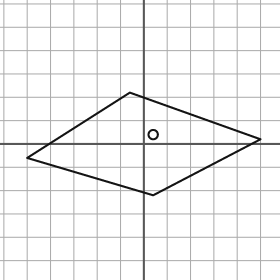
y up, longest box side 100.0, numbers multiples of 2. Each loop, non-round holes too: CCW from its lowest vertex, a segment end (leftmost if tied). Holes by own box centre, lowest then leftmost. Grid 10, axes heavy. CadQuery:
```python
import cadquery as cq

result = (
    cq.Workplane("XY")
    .moveTo(4.0, -22.0)
    .lineTo(50.0, 2.0)
    .lineTo(-6.0, 22.0)
    .lineTo(-50.0, -6.0)
    .close()
    .moveTo(4.0, 4.0)
    .circle(2.0)
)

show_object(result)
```